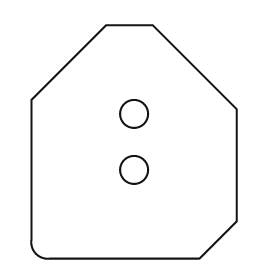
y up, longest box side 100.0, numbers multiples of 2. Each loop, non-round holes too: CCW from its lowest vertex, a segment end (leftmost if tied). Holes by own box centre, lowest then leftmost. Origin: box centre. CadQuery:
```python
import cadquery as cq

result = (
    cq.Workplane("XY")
    .moveTo(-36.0, -50.0)
    .lineTo(28.0, -50.0)
    .lineTo(44.0, -34.0)
    .lineTo(44.0, 14.0)
    .lineTo(8.0, 50.0)
    .lineTo(-12.0, 50.0)
    .lineTo(-44.0, 18.0)
    .lineTo(-44.0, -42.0)
    .threePointArc((-42.0, -48.0), (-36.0, -50.0))
    .close()
    .moveTo(0.0, -12.0)
    .circle(6.0)
    .moveTo(0.0, 12.0)
    .circle(6.0)
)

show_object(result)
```